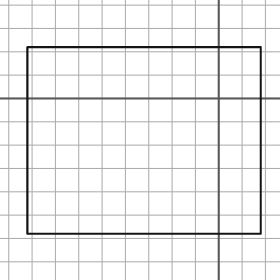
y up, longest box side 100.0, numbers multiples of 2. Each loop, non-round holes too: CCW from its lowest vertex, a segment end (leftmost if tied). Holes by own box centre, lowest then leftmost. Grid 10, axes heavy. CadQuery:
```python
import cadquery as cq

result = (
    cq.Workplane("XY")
    .moveTo(-82.0, -58.0)
    .lineTo(18.0, -58.0)
    .lineTo(18.0, 22.0)
    .lineTo(-82.0, 22.0)
    .close()
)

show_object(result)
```